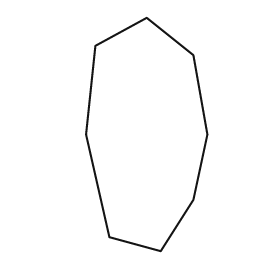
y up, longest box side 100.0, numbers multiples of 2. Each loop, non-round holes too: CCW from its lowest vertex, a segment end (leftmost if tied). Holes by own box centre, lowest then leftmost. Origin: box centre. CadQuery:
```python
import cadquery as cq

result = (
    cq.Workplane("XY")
    .moveTo(6.0, -50.0)
    .lineTo(20.0, -28.0)
    .lineTo(26.0, 0.0)
    .lineTo(20.0, 34.0)
    .lineTo(0.0, 50.0)
    .lineTo(-22.0, 38.0)
    .lineTo(-26.0, 0.0)
    .lineTo(-16.0, -44.0)
    .close()
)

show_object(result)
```